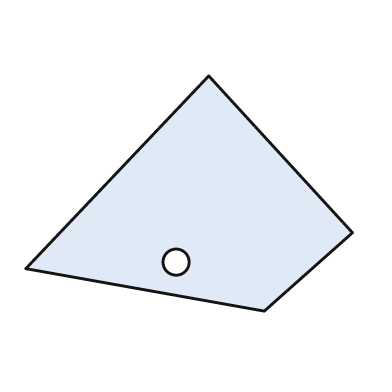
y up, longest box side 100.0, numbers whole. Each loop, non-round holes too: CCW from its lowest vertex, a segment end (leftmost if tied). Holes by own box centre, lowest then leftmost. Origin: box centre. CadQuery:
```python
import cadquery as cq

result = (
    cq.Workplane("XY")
    .moveTo(23.0, -36.0)
    .lineTo(50.0, -12.0)
    .lineTo(6.0, 36.0)
    .lineTo(-50.0, -23.0)
    .close()
    .moveTo(-4.0, -21.0)
    .circle(4.0)
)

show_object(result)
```